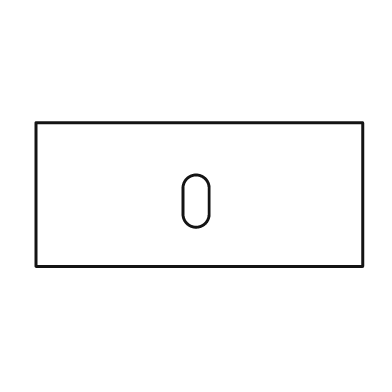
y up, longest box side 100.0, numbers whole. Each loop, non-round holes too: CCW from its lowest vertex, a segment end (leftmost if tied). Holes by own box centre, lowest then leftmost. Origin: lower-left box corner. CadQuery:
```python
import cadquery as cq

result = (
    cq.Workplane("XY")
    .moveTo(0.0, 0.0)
    .lineTo(100.0, 0.0)
    .lineTo(100.0, 44.0)
    .lineTo(0.0, 44.0)
    .close()
    .moveTo(45.0, 16.0)
    .threePointArc((49.0, 12.0), (53.0, 16.0))
    .lineTo(53.0, 24.0)
    .threePointArc((49.0, 28.0), (45.0, 24.0))
    .close()
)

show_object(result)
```